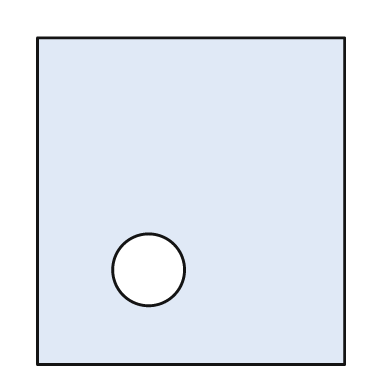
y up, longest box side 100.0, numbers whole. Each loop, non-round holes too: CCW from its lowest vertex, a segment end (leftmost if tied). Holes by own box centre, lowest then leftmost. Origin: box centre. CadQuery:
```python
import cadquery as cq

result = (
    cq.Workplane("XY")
    .moveTo(-47.0, -50.0)
    .lineTo(47.0, -50.0)
    .lineTo(47.0, 50.0)
    .lineTo(-47.0, 50.0)
    .close()
    .moveTo(-13.0, -21.0)
    .circle(11.0)
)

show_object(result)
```